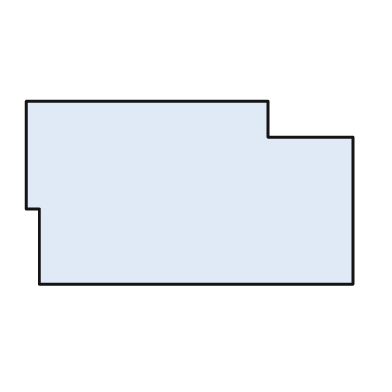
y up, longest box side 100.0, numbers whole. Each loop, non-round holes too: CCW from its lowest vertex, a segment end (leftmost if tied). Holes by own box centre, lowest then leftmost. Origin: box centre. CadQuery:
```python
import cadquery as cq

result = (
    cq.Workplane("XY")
    .moveTo(-46.0, -28.0)
    .lineTo(50.0, -28.0)
    .lineTo(50.0, 17.0)
    .lineTo(24.0, 17.0)
    .lineTo(24.0, 28.0)
    .lineTo(-50.0, 28.0)
    .lineTo(-50.0, -5.0)
    .lineTo(-46.0, -5.0)
    .close()
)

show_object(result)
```